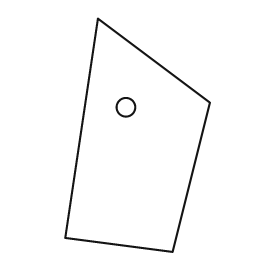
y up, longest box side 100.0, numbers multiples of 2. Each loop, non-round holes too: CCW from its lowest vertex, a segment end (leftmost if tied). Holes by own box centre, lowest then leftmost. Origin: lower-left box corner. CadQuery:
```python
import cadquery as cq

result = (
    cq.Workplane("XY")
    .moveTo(46.0, 0.0)
    .lineTo(62.0, 64.0)
    .lineTo(14.0, 100.0)
    .lineTo(0.0, 6.0)
    .close()
    .moveTo(26.0, 62.0)
    .circle(4.0)
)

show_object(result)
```